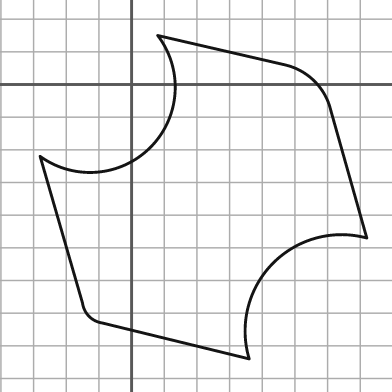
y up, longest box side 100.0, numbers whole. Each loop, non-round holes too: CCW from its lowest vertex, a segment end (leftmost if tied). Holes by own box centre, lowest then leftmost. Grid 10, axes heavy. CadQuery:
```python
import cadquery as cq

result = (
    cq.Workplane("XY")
    .moveTo(36.0, -84.0)
    .threePointArc((43.0, -55.0), (72.0, -47.0))
    .lineTo(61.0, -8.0)
    .threePointArc((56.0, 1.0), (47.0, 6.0))
    .lineTo(8.0, 15.0)
    .threePointArc((6.0, -19.0), (-28.0, -22.0))
    .lineTo(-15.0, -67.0)
    .threePointArc((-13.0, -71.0), (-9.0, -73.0))
    .close()
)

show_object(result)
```